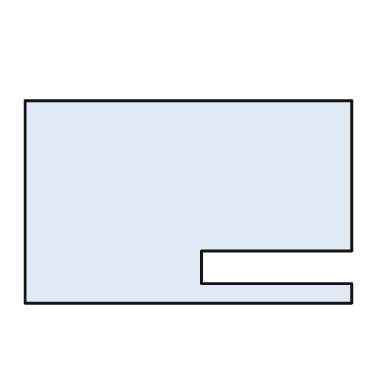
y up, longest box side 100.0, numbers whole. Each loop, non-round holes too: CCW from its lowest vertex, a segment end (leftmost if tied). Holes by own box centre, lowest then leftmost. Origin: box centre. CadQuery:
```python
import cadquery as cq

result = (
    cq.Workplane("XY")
    .moveTo(-50.0, -31.0)
    .lineTo(50.0, -31.0)
    .lineTo(50.0, -25.0)
    .lineTo(4.0, -25.0)
    .lineTo(4.0, -15.0)
    .lineTo(50.0, -15.0)
    .lineTo(50.0, 31.0)
    .lineTo(-50.0, 31.0)
    .close()
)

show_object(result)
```